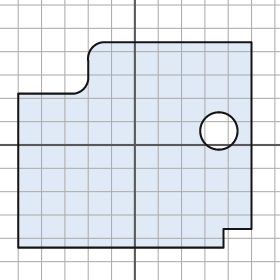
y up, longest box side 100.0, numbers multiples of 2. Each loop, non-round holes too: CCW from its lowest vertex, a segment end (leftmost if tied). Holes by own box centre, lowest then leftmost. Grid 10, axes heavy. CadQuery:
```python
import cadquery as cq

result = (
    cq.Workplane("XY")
    .moveTo(-50.0, -44.0)
    .lineTo(38.0, -44.0)
    .lineTo(38.0, -36.0)
    .lineTo(50.0, -36.0)
    .lineTo(50.0, 44.0)
    .lineTo(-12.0, 44.0)
    .threePointArc((-18.0, 42.0), (-20.0, 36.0))
    .lineTo(-20.0, 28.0)
    .threePointArc((-22.0, 24.0), (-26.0, 22.0))
    .lineTo(-50.0, 22.0)
    .close()
    .moveTo(36.0, 6.0)
    .circle(8.0)
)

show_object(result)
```